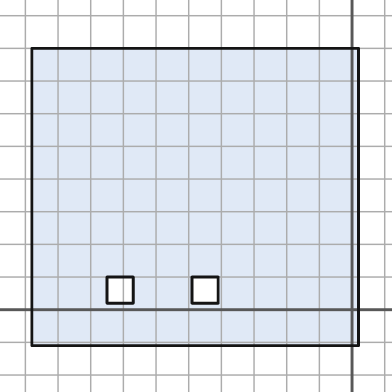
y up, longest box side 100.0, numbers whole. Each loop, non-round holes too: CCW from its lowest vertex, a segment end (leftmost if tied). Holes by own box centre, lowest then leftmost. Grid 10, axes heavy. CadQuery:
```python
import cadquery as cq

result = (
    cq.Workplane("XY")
    .moveTo(-98.0, -11.0)
    .lineTo(2.0, -11.0)
    .lineTo(2.0, 80.0)
    .lineTo(-98.0, 80.0)
    .close()
    .moveTo(-75.0, 2.0)
    .lineTo(-67.0, 2.0)
    .lineTo(-67.0, 10.0)
    .lineTo(-75.0, 10.0)
    .close()
    .moveTo(-49.0, 2.0)
    .lineTo(-41.0, 2.0)
    .lineTo(-41.0, 10.0)
    .lineTo(-49.0, 10.0)
    .close()
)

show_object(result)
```